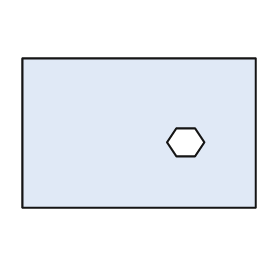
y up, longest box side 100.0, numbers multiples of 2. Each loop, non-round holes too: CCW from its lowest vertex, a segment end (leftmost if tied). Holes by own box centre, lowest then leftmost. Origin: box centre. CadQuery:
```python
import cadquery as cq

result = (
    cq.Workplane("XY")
    .moveTo(-50.0, -32.0)
    .lineTo(50.0, -32.0)
    .lineTo(50.0, 32.0)
    .lineTo(-50.0, 32.0)
    .close()
    .moveTo(16.0, -10.0)
    .lineTo(24.0, -10.0)
    .lineTo(28.0, -4.0)
    .lineTo(24.0, 2.0)
    .lineTo(16.0, 2.0)
    .lineTo(12.0, -4.0)
    .close()
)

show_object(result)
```